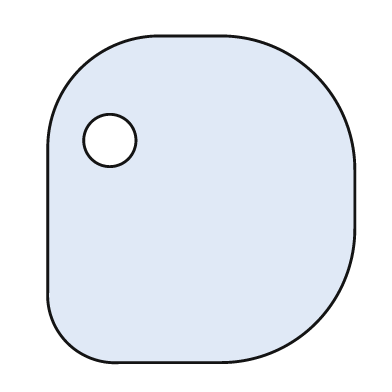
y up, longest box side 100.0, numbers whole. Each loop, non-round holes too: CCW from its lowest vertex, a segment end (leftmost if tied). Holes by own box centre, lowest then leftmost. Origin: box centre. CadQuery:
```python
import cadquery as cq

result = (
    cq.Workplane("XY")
    .moveTo(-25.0, -50.0)
    .lineTo(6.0, -50.0)
    .threePointArc((35.0, -38.0), (47.0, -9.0))
    .lineTo(47.0, 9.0)
    .threePointArc((35.0, 38.0), (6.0, 50.0))
    .lineTo(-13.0, 50.0)
    .threePointArc((-37.0, 40.0), (-47.0, 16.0))
    .lineTo(-47.0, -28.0)
    .threePointArc((-41.0, -44.0), (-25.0, -50.0))
    .close()
    .moveTo(-28.0, 18.0)
    .circle(8.0)
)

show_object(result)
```